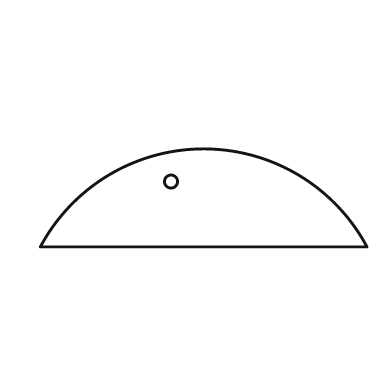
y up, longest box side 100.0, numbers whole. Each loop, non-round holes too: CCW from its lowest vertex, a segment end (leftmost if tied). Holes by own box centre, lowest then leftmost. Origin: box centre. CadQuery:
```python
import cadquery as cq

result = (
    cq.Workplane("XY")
    .moveTo(-50.0, -15.0)
    .lineTo(50.0, -15.0)
    .threePointArc((0.0, 15.0), (-50.0, -15.0))
    .close()
    .moveTo(-10.0, 5.0)
    .circle(2.0)
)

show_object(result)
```